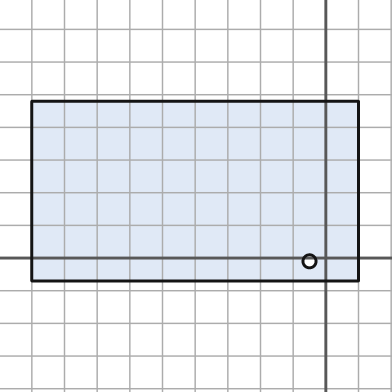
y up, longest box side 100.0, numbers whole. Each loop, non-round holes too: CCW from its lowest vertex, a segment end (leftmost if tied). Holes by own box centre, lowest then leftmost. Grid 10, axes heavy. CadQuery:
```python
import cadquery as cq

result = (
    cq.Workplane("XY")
    .moveTo(-90.0, -7.0)
    .lineTo(10.0, -7.0)
    .lineTo(10.0, 48.0)
    .lineTo(-90.0, 48.0)
    .close()
    .moveTo(-5.0, -1.0)
    .circle(2.0)
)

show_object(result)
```